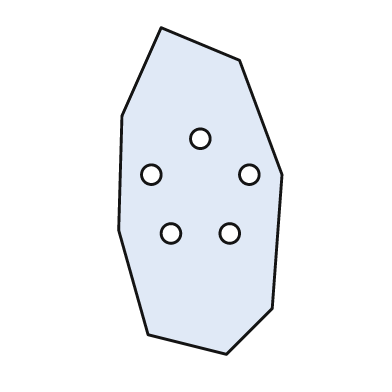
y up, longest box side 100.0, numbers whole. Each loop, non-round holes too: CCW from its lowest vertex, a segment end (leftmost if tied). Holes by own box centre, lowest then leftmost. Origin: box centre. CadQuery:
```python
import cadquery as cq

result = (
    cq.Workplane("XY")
    .moveTo(8.0, -50.0)
    .lineTo(22.0, -36.0)
    .lineTo(25.0, 5.0)
    .lineTo(12.0, 40.0)
    .lineTo(-12.0, 50.0)
    .lineTo(-24.0, 23.0)
    .lineTo(-25.0, -12.0)
    .lineTo(-16.0, -44.0)
    .close()
    .moveTo(-9.0, -13.0)
    .circle(3.0)
    .moveTo(9.0, -13.0)
    .circle(3.0)
    .moveTo(-15.0, 5.0)
    .circle(3.0)
    .moveTo(15.0, 5.0)
    .circle(3.0)
    .moveTo(0.0, 16.0)
    .circle(3.0)
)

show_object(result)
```